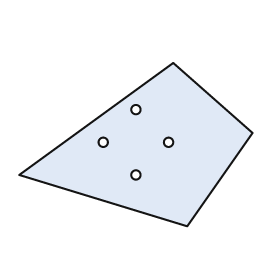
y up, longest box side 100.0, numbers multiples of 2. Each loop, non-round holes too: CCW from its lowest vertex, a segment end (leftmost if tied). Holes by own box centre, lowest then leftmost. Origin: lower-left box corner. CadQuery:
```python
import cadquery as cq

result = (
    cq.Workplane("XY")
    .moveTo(72.0, 0.0)
    .lineTo(100.0, 40.0)
    .lineTo(66.0, 70.0)
    .lineTo(0.0, 22.0)
    .close()
    .moveTo(50.0, 22.0)
    .circle(2.0)
    .moveTo(36.0, 36.0)
    .circle(2.0)
    .moveTo(64.0, 36.0)
    .circle(2.0)
    .moveTo(50.0, 50.0)
    .circle(2.0)
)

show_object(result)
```